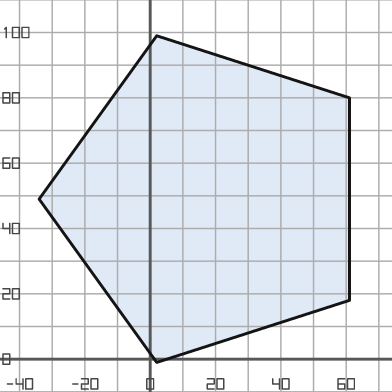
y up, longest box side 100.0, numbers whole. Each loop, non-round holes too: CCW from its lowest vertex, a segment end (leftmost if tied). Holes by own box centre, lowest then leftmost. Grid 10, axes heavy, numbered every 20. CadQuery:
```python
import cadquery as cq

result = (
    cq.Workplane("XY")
    .moveTo(2.0, -1.0)
    .lineTo(61.0, 18.0)
    .lineTo(61.0, 80.0)
    .lineTo(2.0, 99.0)
    .lineTo(-34.0, 49.0)
    .close()
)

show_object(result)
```